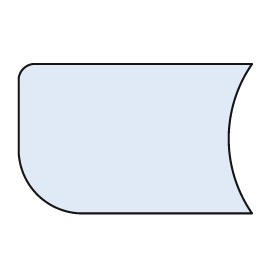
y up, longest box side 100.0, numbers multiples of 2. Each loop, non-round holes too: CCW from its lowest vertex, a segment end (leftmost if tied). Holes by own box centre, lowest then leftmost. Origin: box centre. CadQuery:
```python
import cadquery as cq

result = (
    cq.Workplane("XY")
    .moveTo(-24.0, -32.0)
    .lineTo(50.0, -32.0)
    .threePointArc((40.0, 0.0), (50.0, 32.0))
    .lineTo(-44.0, 32.0)
    .threePointArc((-48.0, 30.0), (-50.0, 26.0))
    .lineTo(-50.0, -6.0)
    .threePointArc((-42.0, -24.0), (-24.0, -32.0))
    .close()
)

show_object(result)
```